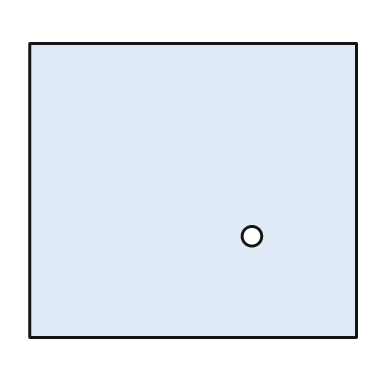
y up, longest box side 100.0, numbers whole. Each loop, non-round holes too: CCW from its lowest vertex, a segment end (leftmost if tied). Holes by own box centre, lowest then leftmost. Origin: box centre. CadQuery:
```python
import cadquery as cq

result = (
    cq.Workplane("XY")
    .moveTo(-50.0, -45.0)
    .lineTo(50.0, -45.0)
    .lineTo(50.0, 45.0)
    .lineTo(-50.0, 45.0)
    .close()
    .moveTo(18.0, -14.0)
    .circle(3.0)
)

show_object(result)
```